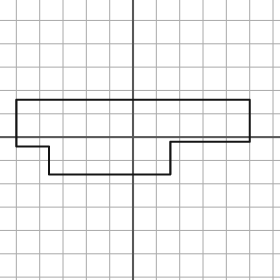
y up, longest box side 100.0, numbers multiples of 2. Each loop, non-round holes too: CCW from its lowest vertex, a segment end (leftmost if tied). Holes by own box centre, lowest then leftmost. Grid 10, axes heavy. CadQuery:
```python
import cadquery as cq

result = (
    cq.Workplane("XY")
    .moveTo(-36.0, -16.0)
    .lineTo(16.0, -16.0)
    .lineTo(16.0, -2.0)
    .lineTo(50.0, -2.0)
    .lineTo(50.0, 16.0)
    .lineTo(-50.0, 16.0)
    .lineTo(-50.0, -4.0)
    .lineTo(-36.0, -4.0)
    .close()
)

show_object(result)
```